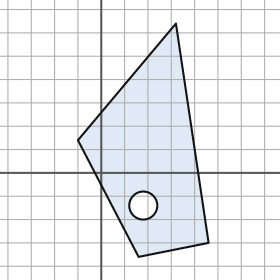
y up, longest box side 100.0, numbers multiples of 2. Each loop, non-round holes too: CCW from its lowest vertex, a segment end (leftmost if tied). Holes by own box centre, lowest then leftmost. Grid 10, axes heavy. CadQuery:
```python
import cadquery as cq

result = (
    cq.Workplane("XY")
    .moveTo(16.0, -36.0)
    .lineTo(46.0, -30.0)
    .lineTo(32.0, 64.0)
    .lineTo(-10.0, 14.0)
    .close()
    .moveTo(18.0, -14.0)
    .circle(6.0)
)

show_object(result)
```